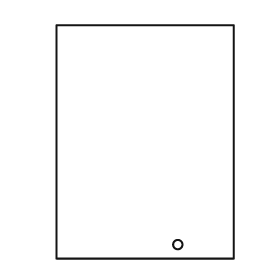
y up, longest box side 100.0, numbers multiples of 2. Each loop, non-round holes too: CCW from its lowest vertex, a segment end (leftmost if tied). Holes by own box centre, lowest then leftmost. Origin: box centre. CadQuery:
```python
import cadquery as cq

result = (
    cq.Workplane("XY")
    .moveTo(-38.0, -50.0)
    .lineTo(38.0, -50.0)
    .lineTo(38.0, 50.0)
    .lineTo(-38.0, 50.0)
    .close()
    .moveTo(14.0, -44.0)
    .circle(2.0)
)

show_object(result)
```